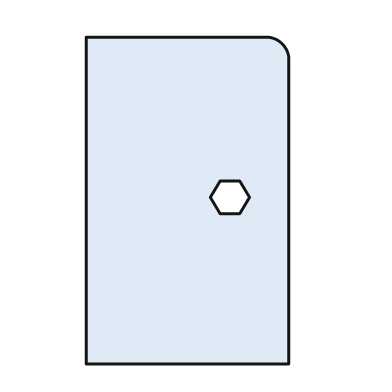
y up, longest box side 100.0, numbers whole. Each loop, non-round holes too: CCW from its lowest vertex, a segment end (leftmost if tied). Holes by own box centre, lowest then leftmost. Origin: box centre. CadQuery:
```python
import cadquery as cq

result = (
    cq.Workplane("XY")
    .moveTo(-31.0, -50.0)
    .lineTo(31.0, -50.0)
    .lineTo(31.0, 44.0)
    .threePointArc((29.0, 48.0), (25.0, 50.0))
    .lineTo(-31.0, 50.0)
    .close()
    .moveTo(10.0, -4.0)
    .lineTo(16.0, -4.0)
    .lineTo(19.0, 1.0)
    .lineTo(16.0, 6.0)
    .lineTo(10.0, 6.0)
    .lineTo(7.0, 1.0)
    .close()
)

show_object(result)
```